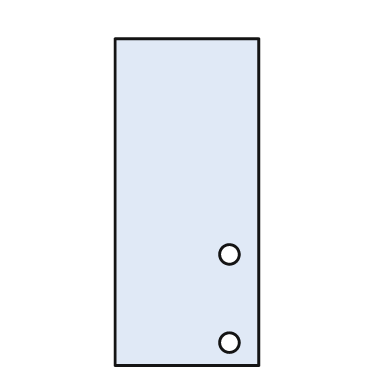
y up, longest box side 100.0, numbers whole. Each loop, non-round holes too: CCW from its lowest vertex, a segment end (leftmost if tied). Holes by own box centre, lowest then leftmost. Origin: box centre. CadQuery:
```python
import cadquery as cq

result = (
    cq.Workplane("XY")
    .moveTo(-22.0, -50.0)
    .lineTo(22.0, -50.0)
    .lineTo(22.0, 50.0)
    .lineTo(-22.0, 50.0)
    .close()
    .moveTo(13.0, -43.0)
    .circle(3.0)
    .moveTo(13.0, -16.0)
    .circle(3.0)
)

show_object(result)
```